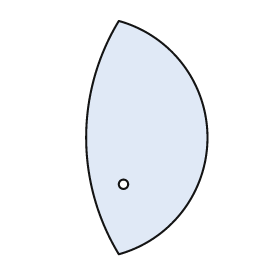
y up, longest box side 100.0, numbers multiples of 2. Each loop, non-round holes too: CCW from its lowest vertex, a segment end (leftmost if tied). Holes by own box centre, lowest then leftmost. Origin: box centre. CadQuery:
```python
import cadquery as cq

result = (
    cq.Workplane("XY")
    .moveTo(-12.0, -50.0)
    .threePointArc((26.0, 0.0), (-12.0, 50.0))
    .threePointArc((-26.0, 0.0), (-12.0, -50.0))
    .close()
    .moveTo(-10.0, -20.0)
    .circle(2.0)
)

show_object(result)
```